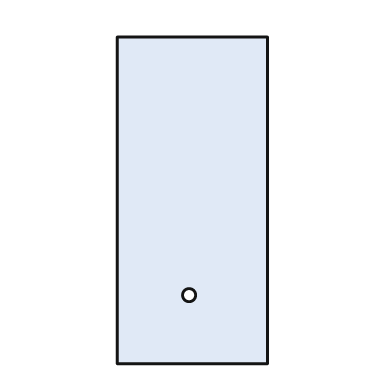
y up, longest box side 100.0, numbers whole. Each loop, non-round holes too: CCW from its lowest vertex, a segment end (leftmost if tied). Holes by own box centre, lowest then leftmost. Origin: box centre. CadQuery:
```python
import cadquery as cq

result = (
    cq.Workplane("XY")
    .moveTo(-23.0, -50.0)
    .lineTo(23.0, -50.0)
    .lineTo(23.0, 50.0)
    .lineTo(-23.0, 50.0)
    .close()
    .moveTo(-1.0, -29.0)
    .circle(2.0)
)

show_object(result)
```